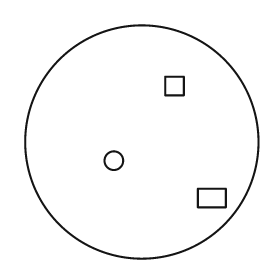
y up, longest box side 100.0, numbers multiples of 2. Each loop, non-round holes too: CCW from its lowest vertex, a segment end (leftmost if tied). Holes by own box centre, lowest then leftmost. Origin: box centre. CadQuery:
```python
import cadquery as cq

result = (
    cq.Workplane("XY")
    .moveTo(0.0, 0.0)
    .circle(50.0)
    .moveTo(24.0, -28.0)
    .lineTo(36.0, -28.0)
    .lineTo(36.0, -20.0)
    .lineTo(24.0, -20.0)
    .close()
    .moveTo(-12.0, -8.0)
    .circle(4.0)
    .moveTo(10.0, 20.0)
    .lineTo(18.0, 20.0)
    .lineTo(18.0, 28.0)
    .lineTo(10.0, 28.0)
    .close()
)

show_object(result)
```